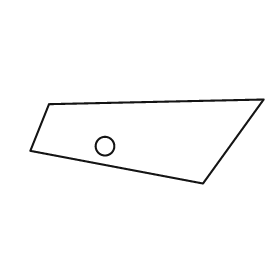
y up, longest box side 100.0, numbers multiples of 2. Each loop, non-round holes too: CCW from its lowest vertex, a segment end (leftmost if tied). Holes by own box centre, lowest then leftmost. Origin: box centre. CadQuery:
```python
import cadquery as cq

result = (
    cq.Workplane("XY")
    .moveTo(24.0, -18.0)
    .lineTo(50.0, 18.0)
    .lineTo(-42.0, 16.0)
    .lineTo(-50.0, -4.0)
    .close()
    .moveTo(-18.0, -2.0)
    .circle(4.0)
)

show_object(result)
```